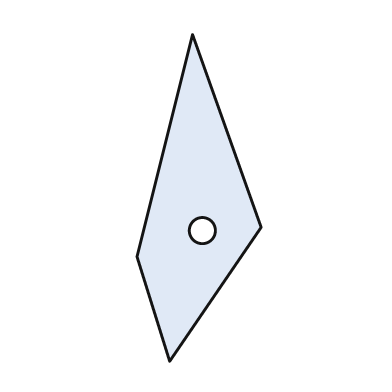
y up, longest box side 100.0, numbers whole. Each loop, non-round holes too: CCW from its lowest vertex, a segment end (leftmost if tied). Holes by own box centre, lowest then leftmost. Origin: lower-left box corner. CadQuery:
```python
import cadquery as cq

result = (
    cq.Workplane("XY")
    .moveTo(10.0, 0.0)
    .lineTo(38.0, 41.0)
    .lineTo(17.0, 100.0)
    .lineTo(0.0, 32.0)
    .close()
    .moveTo(20.0, 40.0)
    .circle(4.0)
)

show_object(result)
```